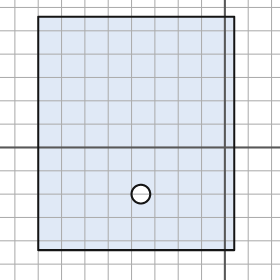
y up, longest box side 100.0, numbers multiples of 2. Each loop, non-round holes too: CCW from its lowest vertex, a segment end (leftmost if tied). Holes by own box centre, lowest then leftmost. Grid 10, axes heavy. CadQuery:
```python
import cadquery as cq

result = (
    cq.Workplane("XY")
    .moveTo(-80.0, -44.0)
    .lineTo(4.0, -44.0)
    .lineTo(4.0, 56.0)
    .lineTo(-80.0, 56.0)
    .close()
    .moveTo(-36.0, -20.0)
    .circle(4.0)
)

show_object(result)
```